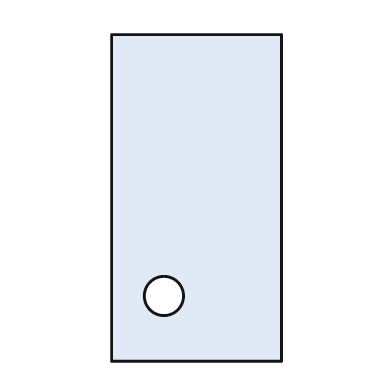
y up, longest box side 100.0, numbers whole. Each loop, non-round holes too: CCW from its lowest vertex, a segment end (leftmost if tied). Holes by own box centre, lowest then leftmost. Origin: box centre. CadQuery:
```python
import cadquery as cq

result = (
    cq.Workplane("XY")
    .moveTo(-26.0, -50.0)
    .lineTo(26.0, -50.0)
    .lineTo(26.0, 50.0)
    .lineTo(-26.0, 50.0)
    .close()
    .moveTo(-10.0, -30.0)
    .circle(6.0)
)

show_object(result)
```